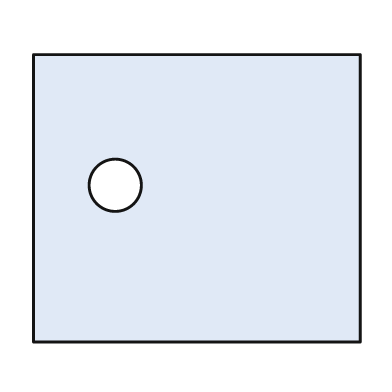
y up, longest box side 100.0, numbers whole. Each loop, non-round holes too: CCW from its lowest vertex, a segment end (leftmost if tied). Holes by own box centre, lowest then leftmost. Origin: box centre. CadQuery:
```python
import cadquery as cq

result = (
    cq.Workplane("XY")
    .moveTo(-50.0, -44.0)
    .lineTo(50.0, -44.0)
    .lineTo(50.0, 44.0)
    .lineTo(-50.0, 44.0)
    .close()
    .moveTo(-25.0, 4.0)
    .circle(8.0)
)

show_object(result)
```